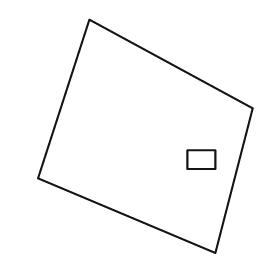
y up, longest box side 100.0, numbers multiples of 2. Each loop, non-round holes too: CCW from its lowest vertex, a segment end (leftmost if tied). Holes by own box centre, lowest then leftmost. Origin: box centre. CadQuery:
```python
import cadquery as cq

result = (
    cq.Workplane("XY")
    .moveTo(30.0, -50.0)
    .lineTo(46.0, 12.0)
    .lineTo(-24.0, 50.0)
    .lineTo(-46.0, -18.0)
    .close()
    .moveTo(18.0, -14.0)
    .lineTo(30.0, -14.0)
    .lineTo(30.0, -6.0)
    .lineTo(18.0, -6.0)
    .close()
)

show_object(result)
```